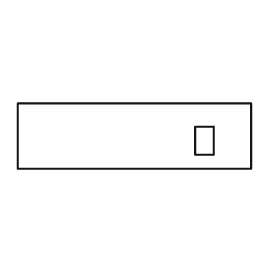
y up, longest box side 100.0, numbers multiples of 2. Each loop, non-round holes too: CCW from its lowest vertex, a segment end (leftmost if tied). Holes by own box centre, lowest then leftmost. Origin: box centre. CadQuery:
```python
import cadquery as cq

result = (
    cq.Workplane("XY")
    .moveTo(-50.0, -14.0)
    .lineTo(50.0, -14.0)
    .lineTo(50.0, 14.0)
    .lineTo(-50.0, 14.0)
    .close()
    .moveTo(26.0, -8.0)
    .lineTo(34.0, -8.0)
    .lineTo(34.0, 4.0)
    .lineTo(26.0, 4.0)
    .close()
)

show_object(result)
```